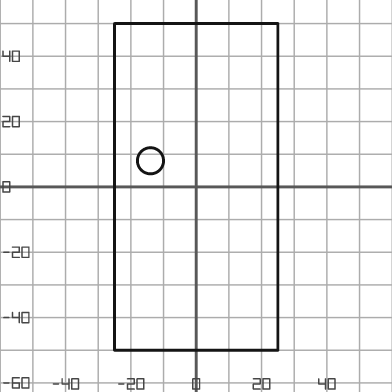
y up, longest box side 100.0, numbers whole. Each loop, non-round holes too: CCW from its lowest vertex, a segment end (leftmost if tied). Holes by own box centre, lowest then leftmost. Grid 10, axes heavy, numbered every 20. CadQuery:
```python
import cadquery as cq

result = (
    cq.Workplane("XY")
    .moveTo(-25.0, -50.0)
    .lineTo(25.0, -50.0)
    .lineTo(25.0, 50.0)
    .lineTo(-25.0, 50.0)
    .close()
    .moveTo(-14.0, 8.0)
    .circle(4.0)
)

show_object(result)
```